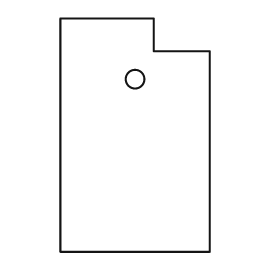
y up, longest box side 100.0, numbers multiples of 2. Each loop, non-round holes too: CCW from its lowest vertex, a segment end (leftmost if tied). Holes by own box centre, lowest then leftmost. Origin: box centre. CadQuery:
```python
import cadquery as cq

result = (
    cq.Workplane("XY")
    .moveTo(-32.0, -50.0)
    .lineTo(32.0, -50.0)
    .lineTo(32.0, 36.0)
    .lineTo(8.0, 36.0)
    .lineTo(8.0, 50.0)
    .lineTo(-32.0, 50.0)
    .close()
    .moveTo(0.0, 24.0)
    .circle(4.0)
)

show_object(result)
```